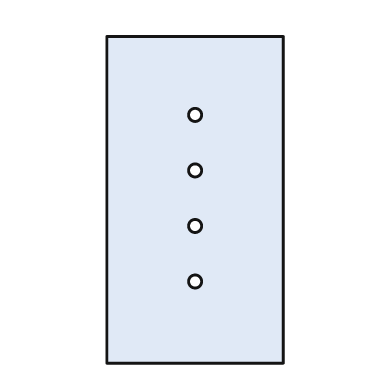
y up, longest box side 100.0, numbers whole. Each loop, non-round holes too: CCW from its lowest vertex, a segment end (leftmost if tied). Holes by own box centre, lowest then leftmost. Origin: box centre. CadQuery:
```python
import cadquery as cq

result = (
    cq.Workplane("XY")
    .moveTo(-27.0, -50.0)
    .lineTo(27.0, -50.0)
    .lineTo(27.0, 50.0)
    .lineTo(-27.0, 50.0)
    .close()
    .moveTo(0.0, -25.0)
    .circle(2.0)
    .moveTo(0.0, -8.0)
    .circle(2.0)
    .moveTo(0.0, 9.0)
    .circle(2.0)
    .moveTo(0.0, 26.0)
    .circle(2.0)
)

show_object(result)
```